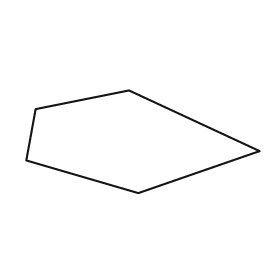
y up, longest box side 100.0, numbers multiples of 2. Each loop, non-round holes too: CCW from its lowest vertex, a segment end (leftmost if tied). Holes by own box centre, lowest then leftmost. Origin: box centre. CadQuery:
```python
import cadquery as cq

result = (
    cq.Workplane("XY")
    .moveTo(-2.0, -22.0)
    .lineTo(50.0, -4.0)
    .lineTo(-6.0, 22.0)
    .lineTo(-46.0, 14.0)
    .lineTo(-50.0, -8.0)
    .close()
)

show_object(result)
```